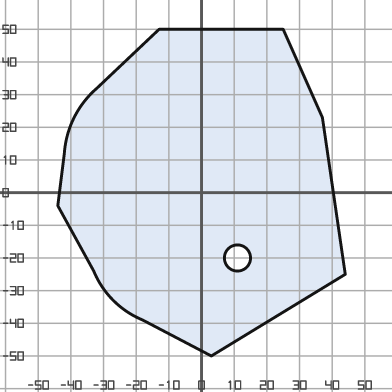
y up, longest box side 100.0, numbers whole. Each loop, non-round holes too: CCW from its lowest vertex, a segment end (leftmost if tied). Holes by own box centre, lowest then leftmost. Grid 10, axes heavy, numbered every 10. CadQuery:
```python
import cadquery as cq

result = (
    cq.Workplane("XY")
    .moveTo(3.0, -50.0)
    .lineTo(44.0, -25.0)
    .lineTo(37.0, 23.0)
    .lineTo(25.0, 50.0)
    .lineTo(-13.0, 50.0)
    .lineTo(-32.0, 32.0)
    .threePointArc((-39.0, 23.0), (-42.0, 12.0))
    .lineTo(-44.0, -4.0)
    .lineTo(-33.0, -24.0)
    .threePointArc((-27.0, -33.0), (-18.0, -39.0))
    .close()
    .moveTo(11.0, -20.0)
    .circle(4.0)
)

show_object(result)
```